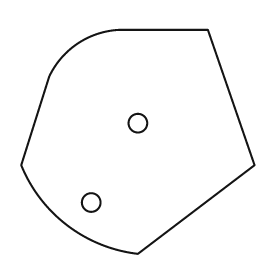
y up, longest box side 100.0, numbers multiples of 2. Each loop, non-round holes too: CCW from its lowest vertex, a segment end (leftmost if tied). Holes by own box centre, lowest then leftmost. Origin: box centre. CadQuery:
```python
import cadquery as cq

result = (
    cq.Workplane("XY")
    .moveTo(0.0, -48.0)
    .lineTo(50.0, -10.0)
    .lineTo(30.0, 48.0)
    .lineTo(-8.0, 48.0)
    .threePointArc((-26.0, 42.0), (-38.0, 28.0))
    .lineTo(-50.0, -10.0)
    .threePointArc((-30.0, -36.0), (0.0, -48.0))
    .close()
    .moveTo(-20.0, -26.0)
    .circle(4.0)
    .moveTo(0.0, 8.0)
    .circle(4.0)
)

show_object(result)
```